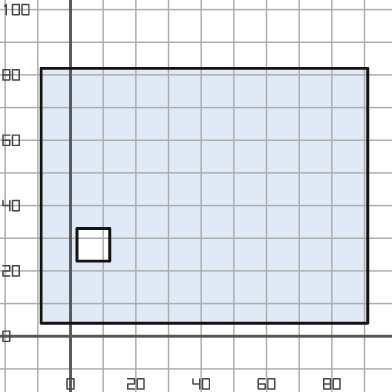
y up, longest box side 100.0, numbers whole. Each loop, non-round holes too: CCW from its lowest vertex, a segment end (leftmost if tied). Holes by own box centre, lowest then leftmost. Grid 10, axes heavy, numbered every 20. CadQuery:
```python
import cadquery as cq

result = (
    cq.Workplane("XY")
    .moveTo(-9.0, 4.0)
    .lineTo(91.0, 4.0)
    .lineTo(91.0, 82.0)
    .lineTo(-9.0, 82.0)
    .close()
    .moveTo(2.0, 23.0)
    .lineTo(12.0, 23.0)
    .lineTo(12.0, 33.0)
    .lineTo(2.0, 33.0)
    .close()
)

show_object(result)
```